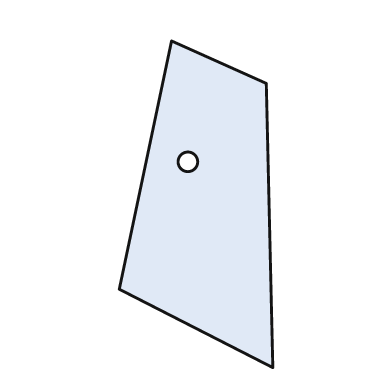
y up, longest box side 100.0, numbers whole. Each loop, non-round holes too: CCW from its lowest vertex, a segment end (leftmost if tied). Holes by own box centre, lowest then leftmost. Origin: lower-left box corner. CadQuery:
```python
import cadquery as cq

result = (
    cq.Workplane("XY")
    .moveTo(47.0, 0.0)
    .lineTo(45.0, 87.0)
    .lineTo(16.0, 100.0)
    .lineTo(0.0, 24.0)
    .close()
    .moveTo(21.0, 63.0)
    .circle(3.0)
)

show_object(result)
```